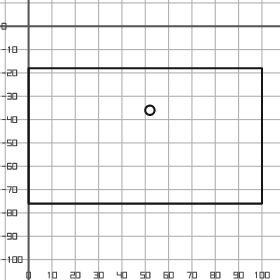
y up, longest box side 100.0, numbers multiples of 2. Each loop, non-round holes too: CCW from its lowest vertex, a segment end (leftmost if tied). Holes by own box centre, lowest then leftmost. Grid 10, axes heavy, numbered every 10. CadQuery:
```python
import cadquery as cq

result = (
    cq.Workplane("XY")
    .moveTo(0.0, -76.0)
    .lineTo(100.0, -76.0)
    .lineTo(100.0, -18.0)
    .lineTo(0.0, -18.0)
    .close()
    .moveTo(52.0, -36.0)
    .circle(2.0)
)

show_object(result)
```